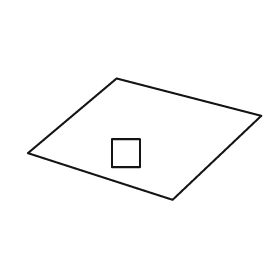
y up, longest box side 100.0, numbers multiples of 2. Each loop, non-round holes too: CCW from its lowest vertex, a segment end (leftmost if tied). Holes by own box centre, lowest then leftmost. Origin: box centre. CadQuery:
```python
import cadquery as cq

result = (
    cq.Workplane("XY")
    .moveTo(12.0, -26.0)
    .lineTo(50.0, 10.0)
    .lineTo(-12.0, 26.0)
    .lineTo(-50.0, -6.0)
    .close()
    .moveTo(-14.0, -12.0)
    .lineTo(-2.0, -12.0)
    .lineTo(-2.0, 0.0)
    .lineTo(-14.0, 0.0)
    .close()
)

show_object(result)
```